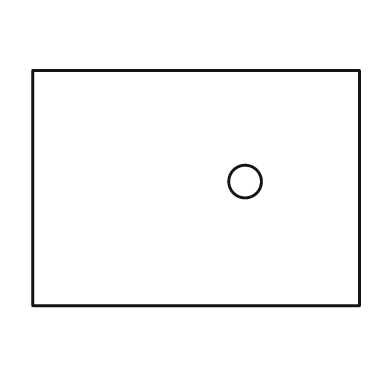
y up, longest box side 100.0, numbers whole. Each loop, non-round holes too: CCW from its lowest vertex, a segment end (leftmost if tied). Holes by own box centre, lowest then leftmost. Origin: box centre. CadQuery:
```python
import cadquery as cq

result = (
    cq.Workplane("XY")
    .moveTo(-50.0, -36.0)
    .lineTo(50.0, -36.0)
    .lineTo(50.0, 36.0)
    .lineTo(-50.0, 36.0)
    .close()
    .moveTo(15.0, 2.0)
    .circle(5.0)
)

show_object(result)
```